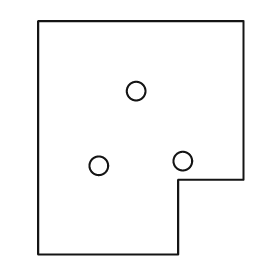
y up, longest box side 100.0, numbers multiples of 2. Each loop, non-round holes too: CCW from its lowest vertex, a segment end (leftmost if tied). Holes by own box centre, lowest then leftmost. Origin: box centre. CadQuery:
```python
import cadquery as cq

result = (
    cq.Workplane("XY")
    .moveTo(-44.0, -50.0)
    .lineTo(16.0, -50.0)
    .lineTo(16.0, -18.0)
    .lineTo(44.0, -18.0)
    .lineTo(44.0, 50.0)
    .lineTo(-44.0, 50.0)
    .close()
    .moveTo(-18.0, -12.0)
    .circle(4.0)
    .moveTo(18.0, -10.0)
    .circle(4.0)
    .moveTo(-2.0, 20.0)
    .circle(4.0)
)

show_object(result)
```